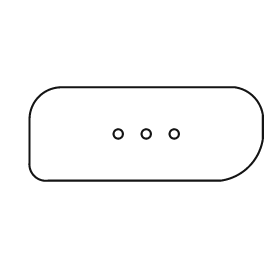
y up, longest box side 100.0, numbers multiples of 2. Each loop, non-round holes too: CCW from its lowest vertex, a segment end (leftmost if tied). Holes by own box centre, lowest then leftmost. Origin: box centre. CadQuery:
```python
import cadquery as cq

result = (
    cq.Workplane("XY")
    .moveTo(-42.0, -20.0)
    .lineTo(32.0, -20.0)
    .threePointArc((44.0, -14.0), (50.0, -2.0))
    .lineTo(50.0, 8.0)
    .threePointArc((46.0, 16.0), (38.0, 20.0))
    .lineTo(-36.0, 20.0)
    .threePointArc((-46.0, 16.0), (-50.0, 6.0))
    .lineTo(-50.0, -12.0)
    .threePointArc((-48.0, -18.0), (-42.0, -20.0))
    .close()
    .moveTo(-12.0, 0.0)
    .circle(2.0)
    .moveTo(0.0, 0.0)
    .circle(2.0)
    .moveTo(12.0, 0.0)
    .circle(2.0)
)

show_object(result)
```